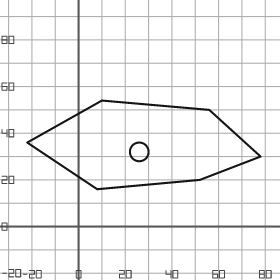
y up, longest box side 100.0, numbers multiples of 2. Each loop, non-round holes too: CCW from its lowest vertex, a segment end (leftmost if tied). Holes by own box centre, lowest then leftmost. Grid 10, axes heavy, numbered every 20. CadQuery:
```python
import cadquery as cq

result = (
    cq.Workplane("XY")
    .moveTo(8.0, 16.0)
    .lineTo(52.0, 20.0)
    .lineTo(78.0, 30.0)
    .lineTo(56.0, 50.0)
    .lineTo(10.0, 54.0)
    .lineTo(-22.0, 36.0)
    .close()
    .moveTo(26.0, 32.0)
    .circle(4.0)
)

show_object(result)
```